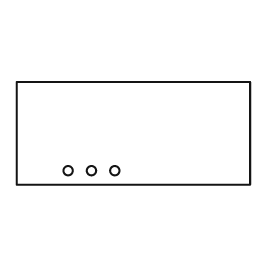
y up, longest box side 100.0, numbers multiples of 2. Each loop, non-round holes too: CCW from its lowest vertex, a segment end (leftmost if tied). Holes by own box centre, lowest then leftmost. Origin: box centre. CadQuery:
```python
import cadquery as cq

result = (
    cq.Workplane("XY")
    .moveTo(-50.0, -22.0)
    .lineTo(50.0, -22.0)
    .lineTo(50.0, 22.0)
    .lineTo(-50.0, 22.0)
    .close()
    .moveTo(-28.0, -16.0)
    .circle(2.0)
    .moveTo(-18.0, -16.0)
    .circle(2.0)
    .moveTo(-8.0, -16.0)
    .circle(2.0)
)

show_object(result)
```